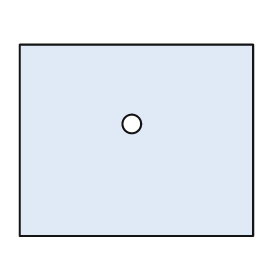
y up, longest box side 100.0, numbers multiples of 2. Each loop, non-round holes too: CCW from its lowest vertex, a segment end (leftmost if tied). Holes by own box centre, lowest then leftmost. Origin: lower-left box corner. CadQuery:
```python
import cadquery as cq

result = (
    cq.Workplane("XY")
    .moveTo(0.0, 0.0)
    .lineTo(100.0, 0.0)
    .lineTo(100.0, 82.0)
    .lineTo(0.0, 82.0)
    .close()
    .moveTo(48.0, 48.0)
    .circle(4.0)
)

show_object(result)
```